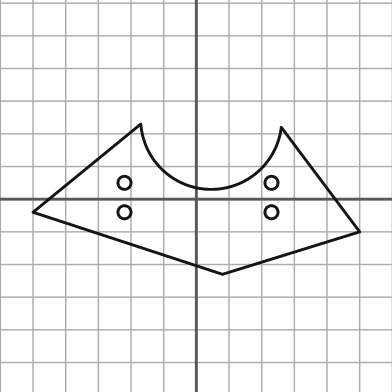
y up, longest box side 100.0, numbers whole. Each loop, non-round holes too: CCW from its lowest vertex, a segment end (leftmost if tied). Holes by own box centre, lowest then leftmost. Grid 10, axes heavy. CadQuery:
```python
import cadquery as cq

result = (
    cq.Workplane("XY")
    .moveTo(8.0, -23.0)
    .lineTo(50.0, -10.0)
    .lineTo(26.0, 22.0)
    .threePointArc((4.0, 3.0), (-17.0, 23.0))
    .lineTo(-50.0, -4.0)
    .close()
    .moveTo(-22.0, -4.0)
    .circle(2.0)
    .moveTo(23.0, -4.0)
    .circle(2.0)
    .moveTo(-22.0, 5.0)
    .circle(2.0)
    .moveTo(23.0, 5.0)
    .circle(2.0)
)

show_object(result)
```